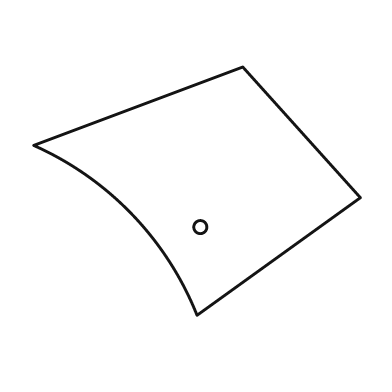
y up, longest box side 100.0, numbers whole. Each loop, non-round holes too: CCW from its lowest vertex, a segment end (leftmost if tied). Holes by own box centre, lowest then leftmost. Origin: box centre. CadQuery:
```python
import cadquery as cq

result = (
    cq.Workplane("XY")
    .moveTo(0.0, -38.0)
    .lineTo(50.0, -2.0)
    .lineTo(14.0, 38.0)
    .lineTo(-50.0, 14.0)
    .threePointArc((-20.0, -7.0), (0.0, -38.0))
    .close()
    .moveTo(1.0, -11.0)
    .circle(2.0)
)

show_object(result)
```